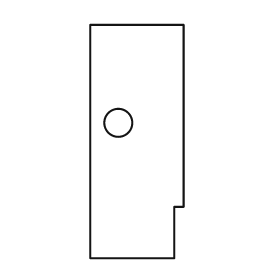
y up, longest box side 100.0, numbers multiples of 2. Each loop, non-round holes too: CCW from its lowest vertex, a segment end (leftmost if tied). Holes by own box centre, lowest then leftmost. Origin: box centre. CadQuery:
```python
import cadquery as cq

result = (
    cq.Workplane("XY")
    .moveTo(-20.0, -50.0)
    .lineTo(16.0, -50.0)
    .lineTo(16.0, -28.0)
    .lineTo(20.0, -28.0)
    .lineTo(20.0, 50.0)
    .lineTo(-20.0, 50.0)
    .close()
    .moveTo(-8.0, 8.0)
    .circle(6.0)
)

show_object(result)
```